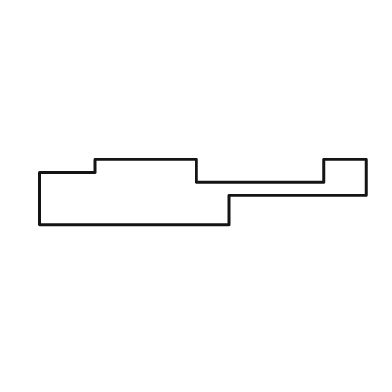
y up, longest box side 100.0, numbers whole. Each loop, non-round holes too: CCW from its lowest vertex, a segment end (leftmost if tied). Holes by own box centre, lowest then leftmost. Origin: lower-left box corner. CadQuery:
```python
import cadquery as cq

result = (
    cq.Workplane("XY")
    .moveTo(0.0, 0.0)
    .lineTo(58.0, 0.0)
    .lineTo(58.0, 9.0)
    .lineTo(100.0, 9.0)
    .lineTo(100.0, 20.0)
    .lineTo(87.0, 20.0)
    .lineTo(87.0, 13.0)
    .lineTo(48.0, 13.0)
    .lineTo(48.0, 20.0)
    .lineTo(17.0, 20.0)
    .lineTo(17.0, 16.0)
    .lineTo(0.0, 16.0)
    .close()
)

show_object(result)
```